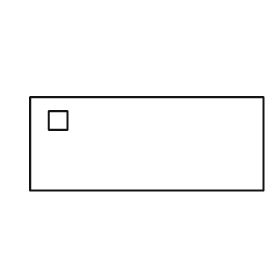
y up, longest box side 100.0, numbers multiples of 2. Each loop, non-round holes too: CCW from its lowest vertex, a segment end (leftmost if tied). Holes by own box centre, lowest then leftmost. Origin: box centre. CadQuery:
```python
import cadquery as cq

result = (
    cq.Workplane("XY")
    .moveTo(-50.0, -20.0)
    .lineTo(50.0, -20.0)
    .lineTo(50.0, 20.0)
    .lineTo(-50.0, 20.0)
    .close()
    .moveTo(-42.0, 6.0)
    .lineTo(-34.0, 6.0)
    .lineTo(-34.0, 14.0)
    .lineTo(-42.0, 14.0)
    .close()
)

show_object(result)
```